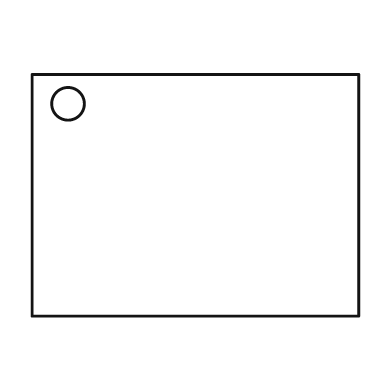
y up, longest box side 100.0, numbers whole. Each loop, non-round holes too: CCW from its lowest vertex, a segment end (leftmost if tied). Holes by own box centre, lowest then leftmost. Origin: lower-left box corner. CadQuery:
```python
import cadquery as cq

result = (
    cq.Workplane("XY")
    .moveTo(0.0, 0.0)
    .lineTo(100.0, 0.0)
    .lineTo(100.0, 74.0)
    .lineTo(0.0, 74.0)
    .close()
    .moveTo(11.0, 65.0)
    .circle(5.0)
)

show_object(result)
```